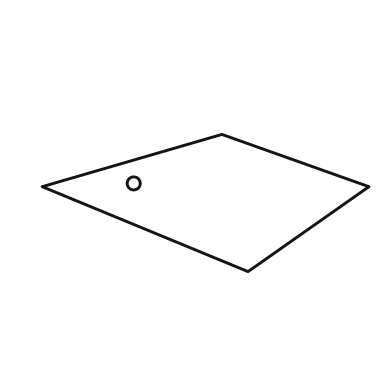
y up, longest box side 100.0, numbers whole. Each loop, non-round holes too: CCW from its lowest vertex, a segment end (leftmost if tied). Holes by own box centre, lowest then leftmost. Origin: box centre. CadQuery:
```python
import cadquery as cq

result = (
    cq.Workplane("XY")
    .moveTo(13.0, -21.0)
    .lineTo(50.0, 5.0)
    .lineTo(5.0, 21.0)
    .lineTo(-50.0, 5.0)
    .close()
    .moveTo(-22.0, 6.0)
    .circle(2.0)
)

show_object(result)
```